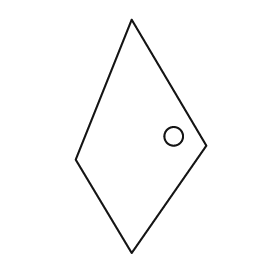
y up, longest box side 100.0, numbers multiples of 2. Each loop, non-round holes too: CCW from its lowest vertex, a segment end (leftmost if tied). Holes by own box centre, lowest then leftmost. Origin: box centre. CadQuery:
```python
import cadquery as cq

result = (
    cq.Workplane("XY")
    .moveTo(-4.0, -50.0)
    .lineTo(28.0, -4.0)
    .lineTo(-4.0, 50.0)
    .lineTo(-28.0, -10.0)
    .close()
    .moveTo(14.0, 0.0)
    .circle(4.0)
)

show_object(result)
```